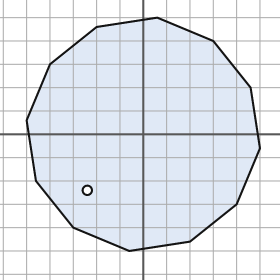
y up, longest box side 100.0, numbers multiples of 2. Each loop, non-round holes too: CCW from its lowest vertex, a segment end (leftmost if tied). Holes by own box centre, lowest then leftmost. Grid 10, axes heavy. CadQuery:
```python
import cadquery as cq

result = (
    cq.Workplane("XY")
    .moveTo(-6.0, -50.0)
    .lineTo(20.0, -46.0)
    .lineTo(40.0, -30.0)
    .lineTo(50.0, -6.0)
    .lineTo(46.0, 20.0)
    .lineTo(30.0, 40.0)
    .lineTo(6.0, 50.0)
    .lineTo(-20.0, 46.0)
    .lineTo(-40.0, 30.0)
    .lineTo(-50.0, 6.0)
    .lineTo(-46.0, -20.0)
    .lineTo(-30.0, -40.0)
    .close()
    .moveTo(-24.0, -24.0)
    .circle(2.0)
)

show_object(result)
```